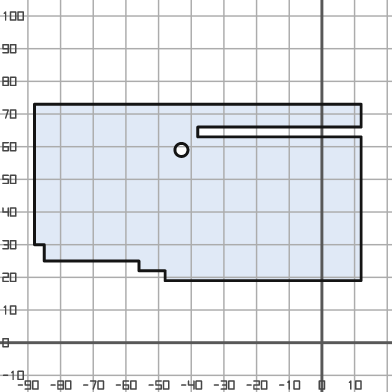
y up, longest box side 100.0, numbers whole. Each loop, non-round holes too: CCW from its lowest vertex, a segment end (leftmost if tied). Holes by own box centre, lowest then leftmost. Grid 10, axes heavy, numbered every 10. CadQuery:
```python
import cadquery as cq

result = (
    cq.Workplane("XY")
    .moveTo(-48.0, 19.0)
    .lineTo(12.0, 19.0)
    .lineTo(12.0, 63.0)
    .lineTo(-38.0, 63.0)
    .lineTo(-38.0, 66.0)
    .lineTo(12.0, 66.0)
    .lineTo(12.0, 73.0)
    .lineTo(-88.0, 73.0)
    .lineTo(-88.0, 30.0)
    .lineTo(-85.0, 30.0)
    .lineTo(-85.0, 25.0)
    .lineTo(-56.0, 25.0)
    .lineTo(-56.0, 22.0)
    .lineTo(-48.0, 22.0)
    .close()
    .moveTo(-43.0, 59.0)
    .circle(2.0)
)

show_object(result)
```